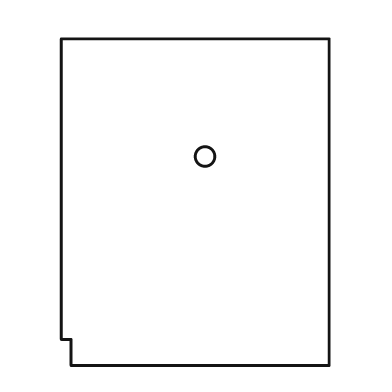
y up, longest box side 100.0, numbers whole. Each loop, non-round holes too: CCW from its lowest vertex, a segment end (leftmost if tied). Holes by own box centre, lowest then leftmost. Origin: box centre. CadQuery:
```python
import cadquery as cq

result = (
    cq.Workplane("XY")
    .moveTo(-38.0, -50.0)
    .lineTo(41.0, -50.0)
    .lineTo(41.0, 50.0)
    .lineTo(-41.0, 50.0)
    .lineTo(-41.0, -42.0)
    .lineTo(-38.0, -42.0)
    .close()
    .moveTo(3.0, 14.0)
    .circle(3.0)
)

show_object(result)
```